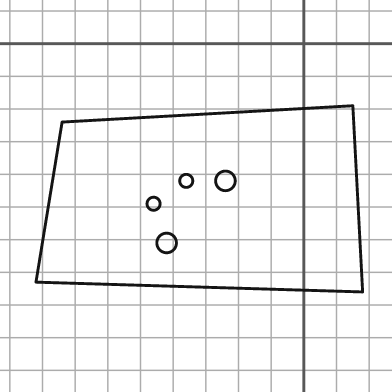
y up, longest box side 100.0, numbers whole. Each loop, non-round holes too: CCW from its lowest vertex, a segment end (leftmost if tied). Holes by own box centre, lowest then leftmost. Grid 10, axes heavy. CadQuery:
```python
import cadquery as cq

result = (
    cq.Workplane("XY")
    .moveTo(18.0, -76.0)
    .lineTo(15.0, -19.0)
    .lineTo(-74.0, -24.0)
    .lineTo(-82.0, -73.0)
    .close()
    .moveTo(-42.0, -61.0)
    .circle(3.0)
    .moveTo(-46.0, -49.0)
    .circle(2.0)
    .moveTo(-36.0, -42.0)
    .circle(2.0)
    .moveTo(-24.0, -42.0)
    .circle(3.0)
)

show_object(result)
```